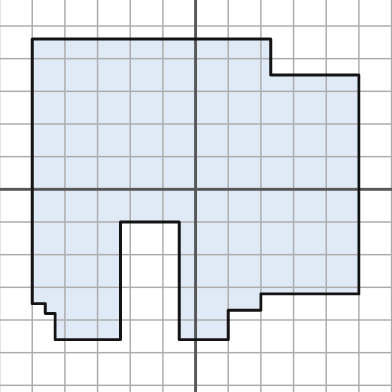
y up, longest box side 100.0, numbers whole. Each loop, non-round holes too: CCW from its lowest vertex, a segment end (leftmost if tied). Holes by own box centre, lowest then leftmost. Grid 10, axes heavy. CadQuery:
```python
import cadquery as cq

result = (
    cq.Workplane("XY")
    .moveTo(-43.0, -46.0)
    .lineTo(-23.0, -46.0)
    .lineTo(-23.0, -10.0)
    .lineTo(-5.0, -10.0)
    .lineTo(-5.0, -46.0)
    .lineTo(10.0, -46.0)
    .lineTo(10.0, -37.0)
    .lineTo(20.0, -37.0)
    .lineTo(20.0, -32.0)
    .lineTo(50.0, -32.0)
    .lineTo(50.0, 35.0)
    .lineTo(23.0, 35.0)
    .lineTo(23.0, 46.0)
    .lineTo(-50.0, 46.0)
    .lineTo(-50.0, -35.0)
    .lineTo(-46.0, -35.0)
    .lineTo(-46.0, -38.0)
    .lineTo(-43.0, -38.0)
    .close()
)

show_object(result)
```